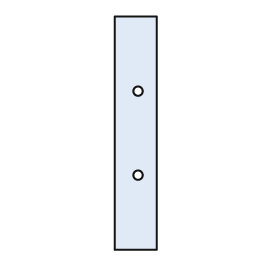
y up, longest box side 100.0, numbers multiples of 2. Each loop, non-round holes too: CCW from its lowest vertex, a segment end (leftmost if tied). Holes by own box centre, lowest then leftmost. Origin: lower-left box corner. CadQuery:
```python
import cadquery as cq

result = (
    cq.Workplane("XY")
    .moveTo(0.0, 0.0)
    .lineTo(18.0, 0.0)
    .lineTo(18.0, 100.0)
    .lineTo(0.0, 100.0)
    .close()
    .moveTo(10.0, 32.0)
    .circle(2.0)
    .moveTo(10.0, 68.0)
    .circle(2.0)
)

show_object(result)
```